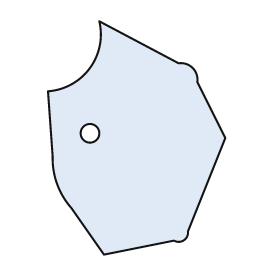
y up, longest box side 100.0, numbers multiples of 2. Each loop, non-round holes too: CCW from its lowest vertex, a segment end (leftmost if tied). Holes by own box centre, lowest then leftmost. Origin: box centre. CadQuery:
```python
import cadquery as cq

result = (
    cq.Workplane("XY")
    .moveTo(-14.0, -50.0)
    .lineTo(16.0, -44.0)
    .threePointArc((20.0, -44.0), (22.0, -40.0))
    .lineTo(38.0, 0.0)
    .lineTo(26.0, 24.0)
    .threePointArc((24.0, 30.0), (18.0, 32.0))
    .lineTo(-16.0, 50.0)
    .threePointArc((-20.0, 30.0), (-38.0, 20.0))
    .lineTo(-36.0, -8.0)
    .threePointArc((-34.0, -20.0), (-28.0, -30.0))
    .close()
    .moveTo(-20.0, 2.0)
    .circle(4.0)
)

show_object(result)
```